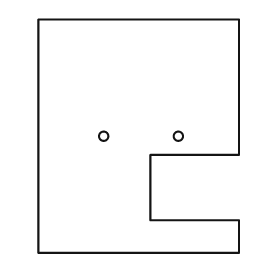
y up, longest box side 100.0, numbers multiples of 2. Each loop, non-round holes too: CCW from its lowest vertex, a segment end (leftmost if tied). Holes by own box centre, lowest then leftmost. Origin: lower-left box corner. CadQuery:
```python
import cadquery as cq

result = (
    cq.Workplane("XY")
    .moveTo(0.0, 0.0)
    .lineTo(86.0, 0.0)
    .lineTo(86.0, 14.0)
    .lineTo(48.0, 14.0)
    .lineTo(48.0, 42.0)
    .lineTo(86.0, 42.0)
    .lineTo(86.0, 100.0)
    .lineTo(0.0, 100.0)
    .close()
    .moveTo(28.0, 50.0)
    .circle(2.0)
    .moveTo(60.0, 50.0)
    .circle(2.0)
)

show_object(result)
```